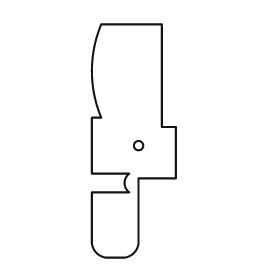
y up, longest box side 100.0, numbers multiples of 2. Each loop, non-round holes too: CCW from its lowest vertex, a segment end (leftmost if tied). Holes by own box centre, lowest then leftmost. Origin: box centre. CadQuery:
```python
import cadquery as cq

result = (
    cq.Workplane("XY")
    .moveTo(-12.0, -50.0)
    .lineTo(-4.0, -50.0)
    .threePointArc((0.0, -48.0), (2.0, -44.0))
    .lineTo(2.0, -16.0)
    .lineTo(18.0, -16.0)
    .lineTo(18.0, 6.0)
    .lineTo(12.0, 6.0)
    .lineTo(12.0, 50.0)
    .lineTo(-14.0, 50.0)
    .threePointArc((-18.0, 30.0), (-14.0, 10.0))
    .lineTo(-18.0, 10.0)
    .lineTo(-18.0, -14.0)
    .lineTo(-2.0, -14.0)
    .threePointArc((-4.0, -18.0), (-2.0, -22.0))
    .lineTo(-18.0, -22.0)
    .lineTo(-18.0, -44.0)
    .threePointArc((-16.0, -48.0), (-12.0, -50.0))
    .close()
    .moveTo(2.0, -2.0)
    .circle(2.0)
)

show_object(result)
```